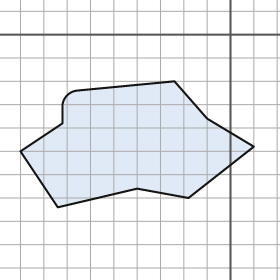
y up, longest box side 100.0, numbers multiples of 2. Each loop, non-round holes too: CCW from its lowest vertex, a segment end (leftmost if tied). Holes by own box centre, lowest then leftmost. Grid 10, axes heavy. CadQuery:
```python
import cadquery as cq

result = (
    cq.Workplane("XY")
    .moveTo(-74.0, -74.0)
    .lineTo(-40.0, -66.0)
    .lineTo(-18.0, -70.0)
    .lineTo(10.0, -48.0)
    .lineTo(-10.0, -36.0)
    .lineTo(-24.0, -20.0)
    .lineTo(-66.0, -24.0)
    .threePointArc((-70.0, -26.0), (-72.0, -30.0))
    .lineTo(-72.0, -38.0)
    .lineTo(-90.0, -50.0)
    .close()
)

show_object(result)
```